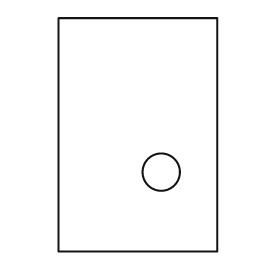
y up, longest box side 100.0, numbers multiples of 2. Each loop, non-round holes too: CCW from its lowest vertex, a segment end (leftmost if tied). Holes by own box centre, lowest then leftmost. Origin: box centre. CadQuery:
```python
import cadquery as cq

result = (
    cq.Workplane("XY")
    .moveTo(-34.0, -50.0)
    .lineTo(34.0, -50.0)
    .lineTo(34.0, 50.0)
    .lineTo(-34.0, 50.0)
    .close()
    .moveTo(10.0, -16.0)
    .circle(8.0)
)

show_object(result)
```